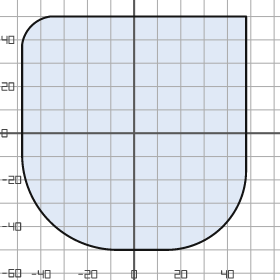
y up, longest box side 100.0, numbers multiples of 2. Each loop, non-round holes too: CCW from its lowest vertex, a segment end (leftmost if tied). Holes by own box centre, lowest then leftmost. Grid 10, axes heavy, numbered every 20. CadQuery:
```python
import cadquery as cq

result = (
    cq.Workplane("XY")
    .moveTo(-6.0, -50.0)
    .lineTo(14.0, -50.0)
    .threePointArc((38.0, -40.0), (48.0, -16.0))
    .lineTo(48.0, 50.0)
    .lineTo(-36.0, 50.0)
    .threePointArc((-44.0, 46.0), (-48.0, 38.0))
    .lineTo(-48.0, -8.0)
    .threePointArc((-36.0, -38.0), (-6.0, -50.0))
    .close()
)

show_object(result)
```